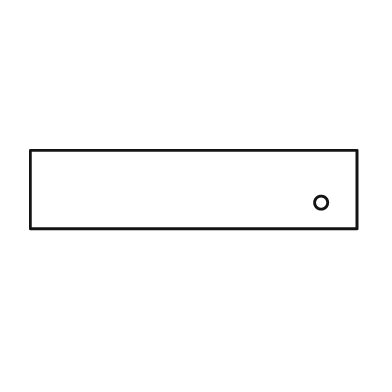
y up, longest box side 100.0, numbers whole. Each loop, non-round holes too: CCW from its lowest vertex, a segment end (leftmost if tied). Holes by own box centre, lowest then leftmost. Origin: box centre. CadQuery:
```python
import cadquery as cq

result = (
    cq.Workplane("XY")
    .moveTo(-50.0, -12.0)
    .lineTo(50.0, -12.0)
    .lineTo(50.0, 12.0)
    .lineTo(-50.0, 12.0)
    .close()
    .moveTo(39.0, -4.0)
    .circle(2.0)
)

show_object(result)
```